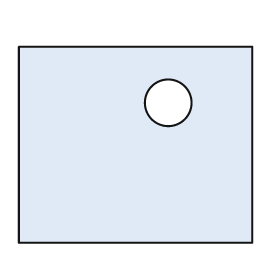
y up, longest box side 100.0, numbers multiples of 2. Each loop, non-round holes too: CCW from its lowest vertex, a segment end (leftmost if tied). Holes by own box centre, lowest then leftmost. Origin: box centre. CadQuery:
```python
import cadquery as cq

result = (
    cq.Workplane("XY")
    .moveTo(-50.0, -42.0)
    .lineTo(50.0, -42.0)
    .lineTo(50.0, 42.0)
    .lineTo(-50.0, 42.0)
    .close()
    .moveTo(14.0, 18.0)
    .circle(10.0)
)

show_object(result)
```